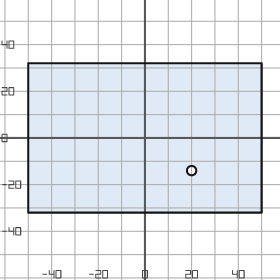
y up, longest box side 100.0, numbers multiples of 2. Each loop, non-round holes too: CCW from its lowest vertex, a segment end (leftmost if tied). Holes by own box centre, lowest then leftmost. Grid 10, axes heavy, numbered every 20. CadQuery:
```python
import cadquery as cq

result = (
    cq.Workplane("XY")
    .moveTo(-50.0, -32.0)
    .lineTo(50.0, -32.0)
    .lineTo(50.0, 32.0)
    .lineTo(-50.0, 32.0)
    .close()
    .moveTo(20.0, -14.0)
    .circle(2.0)
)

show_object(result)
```